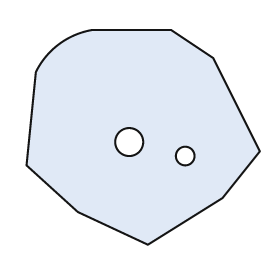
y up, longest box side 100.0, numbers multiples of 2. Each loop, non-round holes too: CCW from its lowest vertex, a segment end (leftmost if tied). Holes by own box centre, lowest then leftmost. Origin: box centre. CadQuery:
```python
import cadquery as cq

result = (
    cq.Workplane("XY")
    .moveTo(2.0, -46.0)
    .lineTo(34.0, -26.0)
    .lineTo(50.0, -6.0)
    .lineTo(30.0, 34.0)
    .lineTo(12.0, 46.0)
    .lineTo(-22.0, 46.0)
    .threePointArc((-36.0, 40.0), (-46.0, 28.0))
    .lineTo(-50.0, -12.0)
    .lineTo(-28.0, -32.0)
    .close()
    .moveTo(18.0, -8.0)
    .circle(4.0)
    .moveTo(-6.0, -2.0)
    .circle(6.0)
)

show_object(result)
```